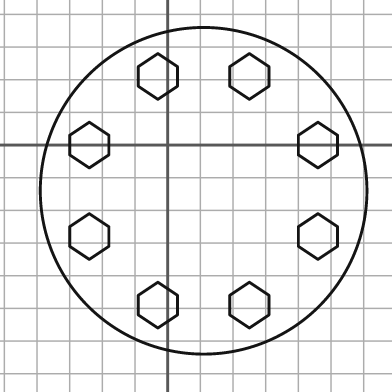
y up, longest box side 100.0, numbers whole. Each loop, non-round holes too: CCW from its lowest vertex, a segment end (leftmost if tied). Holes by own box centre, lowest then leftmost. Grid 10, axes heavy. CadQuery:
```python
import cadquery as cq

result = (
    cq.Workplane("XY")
    .moveTo(11.0, -14.0)
    .circle(50.0)
    .moveTo(-3.0, -56.0)
    .lineTo(3.0, -52.0)
    .lineTo(3.0, -46.0)
    .lineTo(-3.0, -42.0)
    .lineTo(-9.0, -46.0)
    .lineTo(-9.0, -52.0)
    .close()
    .moveTo(25.0, -56.0)
    .lineTo(31.0, -52.0)
    .lineTo(31.0, -46.0)
    .lineTo(25.0, -42.0)
    .lineTo(19.0, -46.0)
    .lineTo(19.0, -52.0)
    .close()
    .moveTo(-24.0, -35.0)
    .lineTo(-18.0, -31.0)
    .lineTo(-18.0, -25.0)
    .lineTo(-24.0, -21.0)
    .lineTo(-30.0, -25.0)
    .lineTo(-30.0, -31.0)
    .close()
    .moveTo(46.0, -35.0)
    .lineTo(52.0, -31.0)
    .lineTo(52.0, -25.0)
    .lineTo(46.0, -21.0)
    .lineTo(40.0, -25.0)
    .lineTo(40.0, -31.0)
    .close()
    .moveTo(-24.0, -7.0)
    .lineTo(-18.0, -3.0)
    .lineTo(-18.0, 3.0)
    .lineTo(-24.0, 7.0)
    .lineTo(-30.0, 3.0)
    .lineTo(-30.0, -3.0)
    .close()
    .moveTo(46.0, -7.0)
    .lineTo(52.0, -3.0)
    .lineTo(52.0, 3.0)
    .lineTo(46.0, 7.0)
    .lineTo(40.0, 3.0)
    .lineTo(40.0, -3.0)
    .close()
    .moveTo(-3.0, 14.0)
    .lineTo(3.0, 18.0)
    .lineTo(3.0, 24.0)
    .lineTo(-3.0, 28.0)
    .lineTo(-9.0, 24.0)
    .lineTo(-9.0, 18.0)
    .close()
    .moveTo(25.0, 14.0)
    .lineTo(31.0, 18.0)
    .lineTo(31.0, 24.0)
    .lineTo(25.0, 28.0)
    .lineTo(19.0, 24.0)
    .lineTo(19.0, 18.0)
    .close()
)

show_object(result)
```